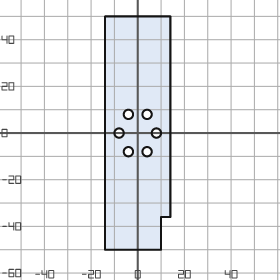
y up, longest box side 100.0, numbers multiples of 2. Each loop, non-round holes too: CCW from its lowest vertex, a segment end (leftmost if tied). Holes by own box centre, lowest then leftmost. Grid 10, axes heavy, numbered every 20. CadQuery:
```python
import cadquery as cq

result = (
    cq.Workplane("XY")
    .moveTo(-14.0, -50.0)
    .lineTo(10.0, -50.0)
    .lineTo(10.0, -36.0)
    .lineTo(14.0, -36.0)
    .lineTo(14.0, 50.0)
    .lineTo(-14.0, 50.0)
    .close()
    .moveTo(-4.0, -8.0)
    .circle(2.0)
    .moveTo(4.0, -8.0)
    .circle(2.0)
    .moveTo(-8.0, 0.0)
    .circle(2.0)
    .moveTo(8.0, 0.0)
    .circle(2.0)
    .moveTo(-4.0, 8.0)
    .circle(2.0)
    .moveTo(4.0, 8.0)
    .circle(2.0)
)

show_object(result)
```